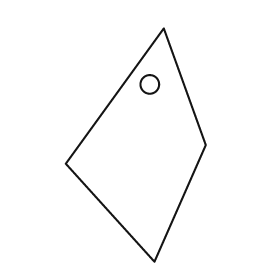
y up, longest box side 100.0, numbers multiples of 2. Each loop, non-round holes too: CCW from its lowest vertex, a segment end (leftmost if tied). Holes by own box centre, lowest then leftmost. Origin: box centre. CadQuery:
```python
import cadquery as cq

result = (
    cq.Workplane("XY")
    .moveTo(8.0, -50.0)
    .lineTo(30.0, 0.0)
    .lineTo(12.0, 50.0)
    .lineTo(-30.0, -8.0)
    .close()
    .moveTo(6.0, 26.0)
    .circle(4.0)
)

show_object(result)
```